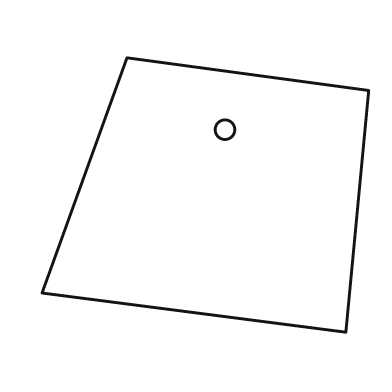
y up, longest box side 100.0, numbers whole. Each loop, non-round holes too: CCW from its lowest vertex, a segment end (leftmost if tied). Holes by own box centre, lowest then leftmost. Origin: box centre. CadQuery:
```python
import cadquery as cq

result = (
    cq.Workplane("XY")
    .moveTo(43.0, -42.0)
    .lineTo(50.0, 32.0)
    .lineTo(-24.0, 42.0)
    .lineTo(-50.0, -30.0)
    .close()
    .moveTo(6.0, 20.0)
    .circle(3.0)
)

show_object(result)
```